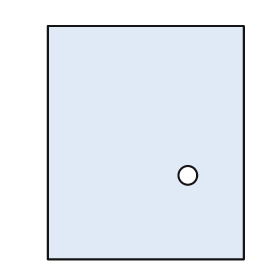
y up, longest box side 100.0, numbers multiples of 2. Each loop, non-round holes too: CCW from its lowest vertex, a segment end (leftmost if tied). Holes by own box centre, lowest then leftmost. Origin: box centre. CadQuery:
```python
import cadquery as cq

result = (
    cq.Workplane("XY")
    .moveTo(-42.0, -50.0)
    .lineTo(42.0, -50.0)
    .lineTo(42.0, 50.0)
    .lineTo(-42.0, 50.0)
    .close()
    .moveTo(18.0, -14.0)
    .circle(4.0)
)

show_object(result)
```